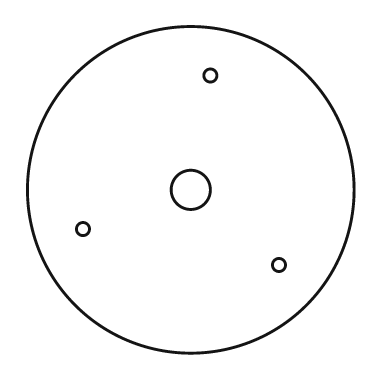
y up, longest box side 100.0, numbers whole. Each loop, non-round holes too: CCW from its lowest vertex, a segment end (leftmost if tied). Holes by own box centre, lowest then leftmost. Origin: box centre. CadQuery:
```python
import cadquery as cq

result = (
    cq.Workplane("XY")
    .moveTo(0.0, 0.0)
    .circle(50.0)
    .moveTo(27.0, -23.0)
    .circle(2.0)
    .moveTo(-33.0, -12.0)
    .circle(2.0)
    .moveTo(0.0, 0.0)
    .circle(6.0)
    .moveTo(6.0, 35.0)
    .circle(2.0)
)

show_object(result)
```